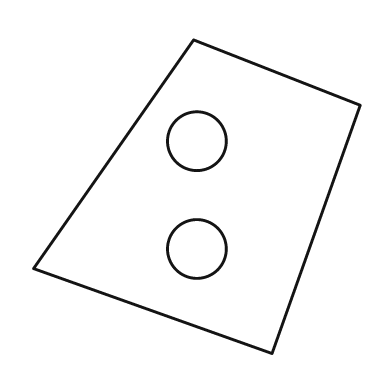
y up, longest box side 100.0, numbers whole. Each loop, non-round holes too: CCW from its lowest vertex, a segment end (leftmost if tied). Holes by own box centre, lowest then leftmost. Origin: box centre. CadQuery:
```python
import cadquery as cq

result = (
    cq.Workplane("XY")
    .moveTo(23.0, -48.0)
    .lineTo(50.0, 28.0)
    .lineTo(-1.0, 48.0)
    .lineTo(-50.0, -22.0)
    .close()
    .moveTo(0.0, -16.0)
    .circle(9.0)
    .moveTo(0.0, 17.0)
    .circle(9.0)
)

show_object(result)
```